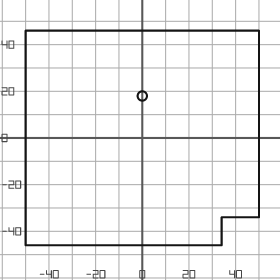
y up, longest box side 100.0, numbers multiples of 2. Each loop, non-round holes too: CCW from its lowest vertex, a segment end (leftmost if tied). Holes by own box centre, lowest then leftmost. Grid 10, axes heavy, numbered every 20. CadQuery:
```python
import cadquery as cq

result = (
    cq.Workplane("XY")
    .moveTo(-50.0, -46.0)
    .lineTo(34.0, -46.0)
    .lineTo(34.0, -34.0)
    .lineTo(50.0, -34.0)
    .lineTo(50.0, 46.0)
    .lineTo(-50.0, 46.0)
    .close()
    .moveTo(0.0, 18.0)
    .circle(2.0)
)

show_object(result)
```